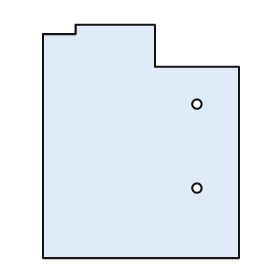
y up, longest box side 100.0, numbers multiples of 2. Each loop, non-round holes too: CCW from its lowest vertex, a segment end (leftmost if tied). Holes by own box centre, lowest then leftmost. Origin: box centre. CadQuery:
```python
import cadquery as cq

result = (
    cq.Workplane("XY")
    .moveTo(-42.0, -50.0)
    .lineTo(42.0, -50.0)
    .lineTo(42.0, 32.0)
    .lineTo(6.0, 32.0)
    .lineTo(6.0, 50.0)
    .lineTo(-28.0, 50.0)
    .lineTo(-28.0, 46.0)
    .lineTo(-42.0, 46.0)
    .close()
    .moveTo(24.0, -20.0)
    .circle(2.0)
    .moveTo(24.0, 16.0)
    .circle(2.0)
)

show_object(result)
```